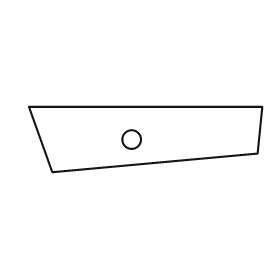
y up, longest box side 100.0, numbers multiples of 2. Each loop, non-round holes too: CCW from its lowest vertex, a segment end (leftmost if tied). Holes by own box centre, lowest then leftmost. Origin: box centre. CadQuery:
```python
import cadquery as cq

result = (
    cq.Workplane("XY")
    .moveTo(-40.0, -14.0)
    .lineTo(48.0, -6.0)
    .lineTo(50.0, 14.0)
    .lineTo(-50.0, 14.0)
    .close()
    .moveTo(-6.0, 0.0)
    .circle(4.0)
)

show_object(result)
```